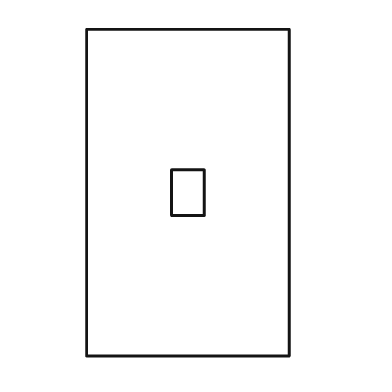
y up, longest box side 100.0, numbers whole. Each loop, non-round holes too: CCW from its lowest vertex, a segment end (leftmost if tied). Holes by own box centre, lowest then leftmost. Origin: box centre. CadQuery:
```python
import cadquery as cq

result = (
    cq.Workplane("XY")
    .moveTo(-31.0, -50.0)
    .lineTo(31.0, -50.0)
    .lineTo(31.0, 50.0)
    .lineTo(-31.0, 50.0)
    .close()
    .moveTo(-5.0, -7.0)
    .lineTo(5.0, -7.0)
    .lineTo(5.0, 7.0)
    .lineTo(-5.0, 7.0)
    .close()
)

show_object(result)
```